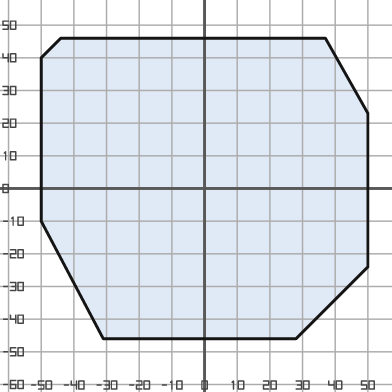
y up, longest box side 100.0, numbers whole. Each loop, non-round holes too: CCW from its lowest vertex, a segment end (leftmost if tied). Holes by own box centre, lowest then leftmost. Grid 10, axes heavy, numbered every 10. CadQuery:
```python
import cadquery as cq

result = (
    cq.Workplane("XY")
    .moveTo(-31.0, -46.0)
    .lineTo(28.0, -46.0)
    .lineTo(50.0, -24.0)
    .lineTo(50.0, 23.0)
    .lineTo(37.0, 46.0)
    .lineTo(-44.0, 46.0)
    .lineTo(-50.0, 40.0)
    .lineTo(-50.0, -10.0)
    .close()
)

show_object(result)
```